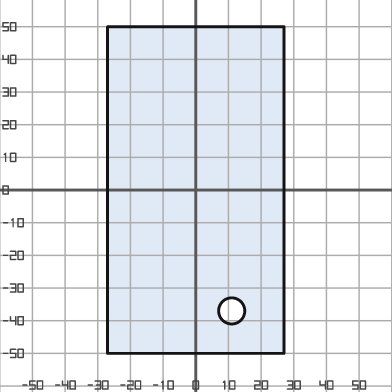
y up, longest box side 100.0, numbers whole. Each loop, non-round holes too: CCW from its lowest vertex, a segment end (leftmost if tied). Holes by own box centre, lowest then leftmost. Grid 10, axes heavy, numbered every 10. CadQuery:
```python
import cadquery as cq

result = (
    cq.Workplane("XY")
    .moveTo(-27.0, -50.0)
    .lineTo(27.0, -50.0)
    .lineTo(27.0, 50.0)
    .lineTo(-27.0, 50.0)
    .close()
    .moveTo(11.0, -37.0)
    .circle(4.0)
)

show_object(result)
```